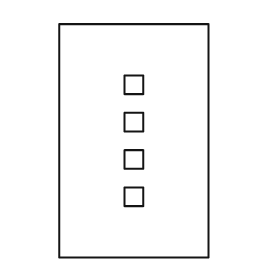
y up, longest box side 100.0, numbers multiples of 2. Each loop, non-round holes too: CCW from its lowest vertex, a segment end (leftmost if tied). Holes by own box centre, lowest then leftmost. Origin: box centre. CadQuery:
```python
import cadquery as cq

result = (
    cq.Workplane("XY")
    .moveTo(-32.0, -50.0)
    .lineTo(32.0, -50.0)
    .lineTo(32.0, 50.0)
    .lineTo(-32.0, 50.0)
    .close()
    .moveTo(-4.0, -28.0)
    .lineTo(4.0, -28.0)
    .lineTo(4.0, -20.0)
    .lineTo(-4.0, -20.0)
    .close()
    .moveTo(-4.0, -12.0)
    .lineTo(4.0, -12.0)
    .lineTo(4.0, -4.0)
    .lineTo(-4.0, -4.0)
    .close()
    .moveTo(-4.0, 4.0)
    .lineTo(4.0, 4.0)
    .lineTo(4.0, 12.0)
    .lineTo(-4.0, 12.0)
    .close()
    .moveTo(-4.0, 20.0)
    .lineTo(4.0, 20.0)
    .lineTo(4.0, 28.0)
    .lineTo(-4.0, 28.0)
    .close()
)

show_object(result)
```